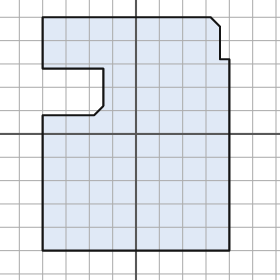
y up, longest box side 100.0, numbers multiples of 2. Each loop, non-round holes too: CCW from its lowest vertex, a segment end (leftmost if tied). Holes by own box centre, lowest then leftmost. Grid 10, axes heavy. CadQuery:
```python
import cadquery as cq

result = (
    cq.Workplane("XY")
    .moveTo(-40.0, -50.0)
    .lineTo(40.0, -50.0)
    .lineTo(40.0, 32.0)
    .lineTo(36.0, 32.0)
    .lineTo(36.0, 46.0)
    .lineTo(32.0, 50.0)
    .lineTo(-40.0, 50.0)
    .lineTo(-40.0, 28.0)
    .lineTo(-14.0, 28.0)
    .lineTo(-14.0, 12.0)
    .lineTo(-18.0, 8.0)
    .lineTo(-40.0, 8.0)
    .close()
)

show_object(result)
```